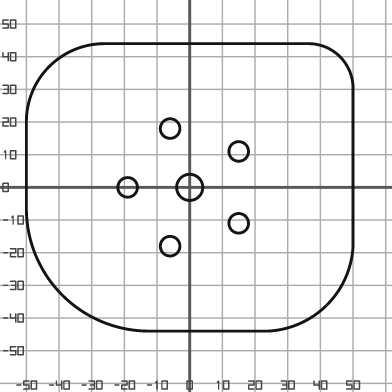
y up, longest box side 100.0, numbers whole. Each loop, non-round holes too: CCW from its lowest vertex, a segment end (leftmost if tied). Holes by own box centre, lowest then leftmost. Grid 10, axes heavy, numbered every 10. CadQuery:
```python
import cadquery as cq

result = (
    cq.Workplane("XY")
    .moveTo(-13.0, -44.0)
    .lineTo(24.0, -44.0)
    .threePointArc((42.0, -36.0), (50.0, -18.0))
    .lineTo(50.0, 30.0)
    .threePointArc((46.0, 40.0), (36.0, 44.0))
    .lineTo(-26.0, 44.0)
    .threePointArc((-43.0, 37.0), (-50.0, 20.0))
    .lineTo(-50.0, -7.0)
    .threePointArc((-39.0, -33.0), (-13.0, -44.0))
    .close()
    .moveTo(-6.0, -18.0)
    .circle(3.0)
    .moveTo(15.0, -11.0)
    .circle(3.0)
    .moveTo(-19.0, 0.0)
    .circle(3.0)
    .moveTo(0.0, 0.0)
    .circle(4.0)
    .moveTo(15.0, 11.0)
    .circle(3.0)
    .moveTo(-6.0, 18.0)
    .circle(3.0)
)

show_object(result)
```